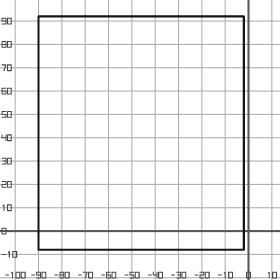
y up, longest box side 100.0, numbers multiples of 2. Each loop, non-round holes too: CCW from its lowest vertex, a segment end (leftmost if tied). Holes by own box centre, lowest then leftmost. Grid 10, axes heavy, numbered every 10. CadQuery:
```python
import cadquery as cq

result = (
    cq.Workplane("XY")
    .moveTo(-90.0, -8.0)
    .lineTo(-2.0, -8.0)
    .lineTo(-2.0, 92.0)
    .lineTo(-90.0, 92.0)
    .close()
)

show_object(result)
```